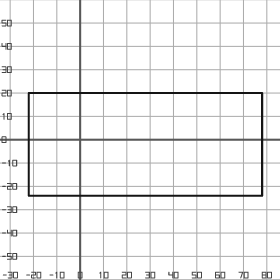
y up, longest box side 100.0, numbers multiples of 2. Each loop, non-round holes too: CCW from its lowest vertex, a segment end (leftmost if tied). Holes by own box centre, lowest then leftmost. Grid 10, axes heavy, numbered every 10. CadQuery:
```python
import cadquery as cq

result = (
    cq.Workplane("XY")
    .moveTo(-22.0, -24.0)
    .lineTo(78.0, -24.0)
    .lineTo(78.0, 20.0)
    .lineTo(-22.0, 20.0)
    .close()
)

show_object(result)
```